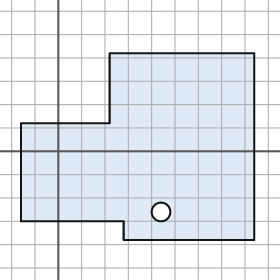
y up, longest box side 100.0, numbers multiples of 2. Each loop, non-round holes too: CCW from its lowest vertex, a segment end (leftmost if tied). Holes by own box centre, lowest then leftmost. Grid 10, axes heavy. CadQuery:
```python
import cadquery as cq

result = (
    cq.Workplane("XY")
    .moveTo(28.0, -38.0)
    .lineTo(84.0, -38.0)
    .lineTo(84.0, 42.0)
    .lineTo(22.0, 42.0)
    .lineTo(22.0, 12.0)
    .lineTo(-16.0, 12.0)
    .lineTo(-16.0, -30.0)
    .lineTo(28.0, -30.0)
    .close()
    .moveTo(44.0, -26.0)
    .circle(4.0)
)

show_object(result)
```